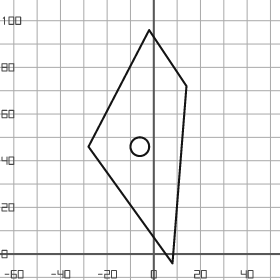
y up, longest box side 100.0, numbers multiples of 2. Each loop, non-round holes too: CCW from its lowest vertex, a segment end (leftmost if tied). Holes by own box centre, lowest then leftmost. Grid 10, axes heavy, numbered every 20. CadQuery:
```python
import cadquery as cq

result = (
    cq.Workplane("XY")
    .moveTo(8.0, -4.0)
    .lineTo(14.0, 72.0)
    .lineTo(-2.0, 96.0)
    .lineTo(-28.0, 46.0)
    .close()
    .moveTo(-6.0, 46.0)
    .circle(4.0)
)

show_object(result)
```